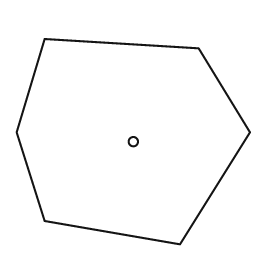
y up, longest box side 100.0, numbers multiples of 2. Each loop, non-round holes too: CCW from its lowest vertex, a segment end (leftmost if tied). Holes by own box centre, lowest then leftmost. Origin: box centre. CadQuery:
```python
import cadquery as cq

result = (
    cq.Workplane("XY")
    .moveTo(20.0, -44.0)
    .lineTo(50.0, 4.0)
    .lineTo(28.0, 40.0)
    .lineTo(-38.0, 44.0)
    .lineTo(-50.0, 4.0)
    .lineTo(-38.0, -34.0)
    .close()
    .moveTo(0.0, 0.0)
    .circle(2.0)
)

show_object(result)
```